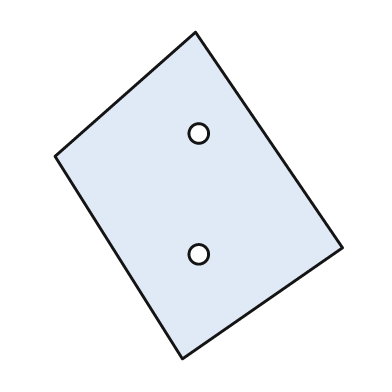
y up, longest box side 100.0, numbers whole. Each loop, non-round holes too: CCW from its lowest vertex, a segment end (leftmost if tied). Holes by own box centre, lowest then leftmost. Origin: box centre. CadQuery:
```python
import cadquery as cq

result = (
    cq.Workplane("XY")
    .moveTo(-5.0, -50.0)
    .lineTo(44.0, -16.0)
    .lineTo(-1.0, 50.0)
    .lineTo(-44.0, 12.0)
    .close()
    .moveTo(0.0, -18.0)
    .circle(3.0)
    .moveTo(0.0, 19.0)
    .circle(3.0)
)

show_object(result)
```